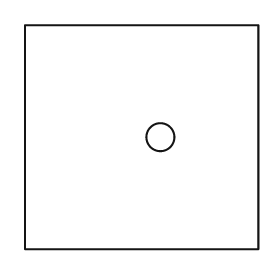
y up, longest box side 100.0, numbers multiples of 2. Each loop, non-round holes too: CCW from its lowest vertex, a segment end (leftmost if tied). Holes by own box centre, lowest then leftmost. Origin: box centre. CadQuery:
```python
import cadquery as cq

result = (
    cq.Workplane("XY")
    .moveTo(-50.0, -48.0)
    .lineTo(50.0, -48.0)
    .lineTo(50.0, 48.0)
    .lineTo(-50.0, 48.0)
    .close()
    .moveTo(8.0, 0.0)
    .circle(6.0)
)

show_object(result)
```